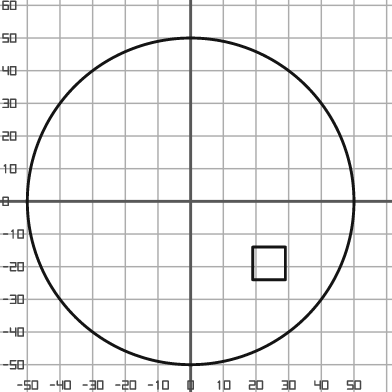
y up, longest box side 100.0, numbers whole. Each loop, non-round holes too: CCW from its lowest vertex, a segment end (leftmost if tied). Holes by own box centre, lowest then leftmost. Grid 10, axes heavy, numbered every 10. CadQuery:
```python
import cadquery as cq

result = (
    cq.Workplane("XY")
    .moveTo(0.0, 0.0)
    .circle(50.0)
    .moveTo(19.0, -24.0)
    .lineTo(29.0, -24.0)
    .lineTo(29.0, -14.0)
    .lineTo(19.0, -14.0)
    .close()
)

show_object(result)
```